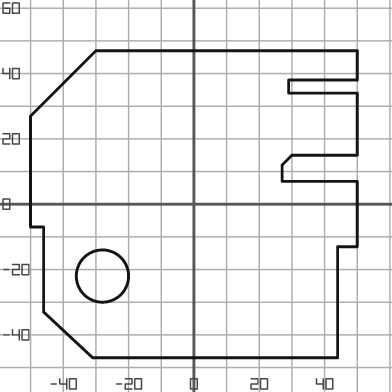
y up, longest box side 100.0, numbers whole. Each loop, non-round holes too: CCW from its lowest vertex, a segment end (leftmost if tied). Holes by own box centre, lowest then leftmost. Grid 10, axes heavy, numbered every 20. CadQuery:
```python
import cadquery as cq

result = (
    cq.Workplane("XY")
    .moveTo(-31.0, -47.0)
    .lineTo(44.0, -47.0)
    .lineTo(44.0, -13.0)
    .lineTo(50.0, -13.0)
    .lineTo(50.0, 7.0)
    .lineTo(27.0, 7.0)
    .lineTo(27.0, 12.0)
    .lineTo(30.0, 15.0)
    .lineTo(50.0, 15.0)
    .lineTo(50.0, 34.0)
    .lineTo(29.0, 34.0)
    .lineTo(29.0, 38.0)
    .lineTo(50.0, 38.0)
    .lineTo(50.0, 47.0)
    .lineTo(-30.0, 47.0)
    .lineTo(-50.0, 27.0)
    .lineTo(-50.0, -7.0)
    .lineTo(-46.0, -7.0)
    .lineTo(-46.0, -33.0)
    .close()
    .moveTo(-28.0, -22.0)
    .circle(8.0)
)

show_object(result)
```